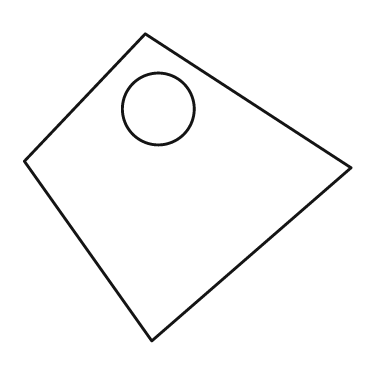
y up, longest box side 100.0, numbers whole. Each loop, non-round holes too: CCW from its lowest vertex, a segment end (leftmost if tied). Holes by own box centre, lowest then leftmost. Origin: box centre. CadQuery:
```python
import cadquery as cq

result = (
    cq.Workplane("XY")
    .moveTo(-11.0, -47.0)
    .lineTo(50.0, 6.0)
    .lineTo(-13.0, 47.0)
    .lineTo(-50.0, 8.0)
    .close()
    .moveTo(-9.0, 24.0)
    .circle(11.0)
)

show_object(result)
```